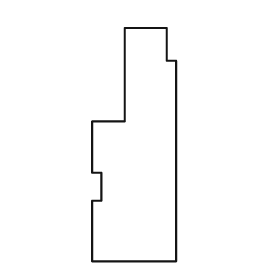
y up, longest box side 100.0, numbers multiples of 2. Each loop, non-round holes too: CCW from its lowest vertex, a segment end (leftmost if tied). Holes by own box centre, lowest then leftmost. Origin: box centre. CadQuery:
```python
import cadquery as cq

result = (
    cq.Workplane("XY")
    .moveTo(-18.0, -50.0)
    .lineTo(18.0, -50.0)
    .lineTo(18.0, 36.0)
    .lineTo(14.0, 36.0)
    .lineTo(14.0, 50.0)
    .lineTo(-4.0, 50.0)
    .lineTo(-4.0, 10.0)
    .lineTo(-18.0, 10.0)
    .lineTo(-18.0, -12.0)
    .lineTo(-14.0, -12.0)
    .lineTo(-14.0, -24.0)
    .lineTo(-18.0, -24.0)
    .close()
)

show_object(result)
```